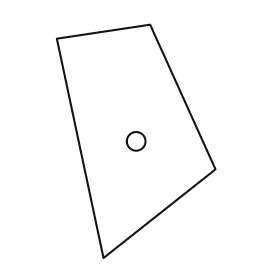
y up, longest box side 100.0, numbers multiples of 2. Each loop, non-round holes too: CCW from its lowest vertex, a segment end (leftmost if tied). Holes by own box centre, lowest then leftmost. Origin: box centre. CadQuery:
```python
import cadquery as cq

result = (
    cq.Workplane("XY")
    .moveTo(-14.0, -50.0)
    .lineTo(34.0, -12.0)
    .lineTo(6.0, 50.0)
    .lineTo(-34.0, 44.0)
    .close()
    .moveTo(0.0, 0.0)
    .circle(4.0)
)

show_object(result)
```